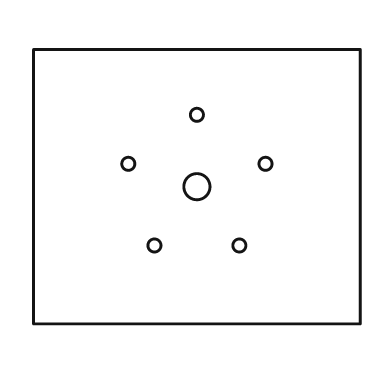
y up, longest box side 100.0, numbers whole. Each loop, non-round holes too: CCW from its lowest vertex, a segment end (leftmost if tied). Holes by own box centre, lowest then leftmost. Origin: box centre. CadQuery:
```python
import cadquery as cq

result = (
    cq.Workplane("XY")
    .moveTo(-50.0, -42.0)
    .lineTo(50.0, -42.0)
    .lineTo(50.0, 42.0)
    .lineTo(-50.0, 42.0)
    .close()
    .moveTo(-13.0, -18.0)
    .circle(2.0)
    .moveTo(13.0, -18.0)
    .circle(2.0)
    .moveTo(0.0, 0.0)
    .circle(4.0)
    .moveTo(-21.0, 7.0)
    .circle(2.0)
    .moveTo(21.0, 7.0)
    .circle(2.0)
    .moveTo(0.0, 22.0)
    .circle(2.0)
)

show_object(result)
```